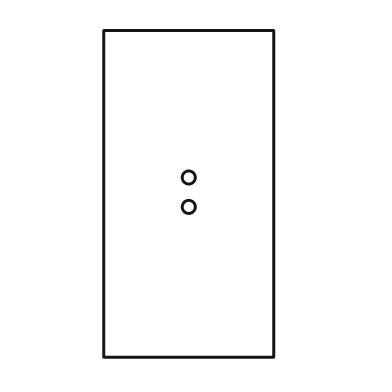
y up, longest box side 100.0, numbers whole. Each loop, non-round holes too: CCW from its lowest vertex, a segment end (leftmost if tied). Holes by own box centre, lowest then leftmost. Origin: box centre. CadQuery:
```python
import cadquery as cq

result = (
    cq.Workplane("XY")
    .moveTo(-26.0, -50.0)
    .lineTo(26.0, -50.0)
    .lineTo(26.0, 50.0)
    .lineTo(-26.0, 50.0)
    .close()
    .moveTo(0.0, -4.0)
    .circle(2.0)
    .moveTo(0.0, 5.0)
    .circle(2.0)
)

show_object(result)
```